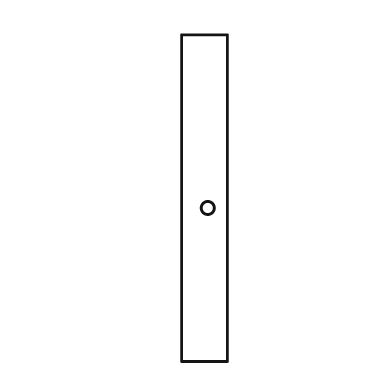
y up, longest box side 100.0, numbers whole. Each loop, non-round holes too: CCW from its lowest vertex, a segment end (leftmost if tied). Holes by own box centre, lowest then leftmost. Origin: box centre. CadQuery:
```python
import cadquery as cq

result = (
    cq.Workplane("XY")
    .moveTo(-7.0, -50.0)
    .lineTo(7.0, -50.0)
    .lineTo(7.0, 50.0)
    .lineTo(-7.0, 50.0)
    .close()
    .moveTo(1.0, -3.0)
    .circle(2.0)
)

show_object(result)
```